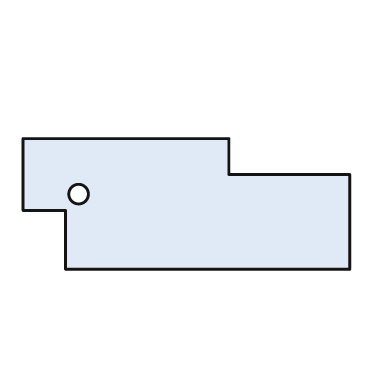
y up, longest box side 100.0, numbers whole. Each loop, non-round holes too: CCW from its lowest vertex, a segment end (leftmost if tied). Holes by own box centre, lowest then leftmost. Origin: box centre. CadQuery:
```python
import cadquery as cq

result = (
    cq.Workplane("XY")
    .moveTo(-37.0, -20.0)
    .lineTo(50.0, -20.0)
    .lineTo(50.0, 9.0)
    .lineTo(13.0, 9.0)
    .lineTo(13.0, 20.0)
    .lineTo(-50.0, 20.0)
    .lineTo(-50.0, -2.0)
    .lineTo(-37.0, -2.0)
    .close()
    .moveTo(-33.0, 3.0)
    .circle(3.0)
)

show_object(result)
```